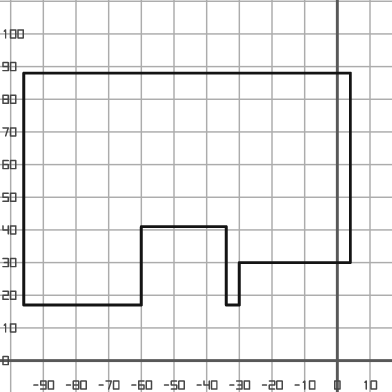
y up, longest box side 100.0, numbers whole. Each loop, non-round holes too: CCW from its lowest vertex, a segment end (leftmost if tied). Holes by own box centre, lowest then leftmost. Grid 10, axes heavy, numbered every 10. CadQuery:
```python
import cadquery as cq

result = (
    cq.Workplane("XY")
    .moveTo(-96.0, 17.0)
    .lineTo(-60.0, 17.0)
    .lineTo(-60.0, 41.0)
    .lineTo(-34.0, 41.0)
    .lineTo(-34.0, 17.0)
    .lineTo(-30.0, 17.0)
    .lineTo(-30.0, 30.0)
    .lineTo(4.0, 30.0)
    .lineTo(4.0, 88.0)
    .lineTo(-96.0, 88.0)
    .close()
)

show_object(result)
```